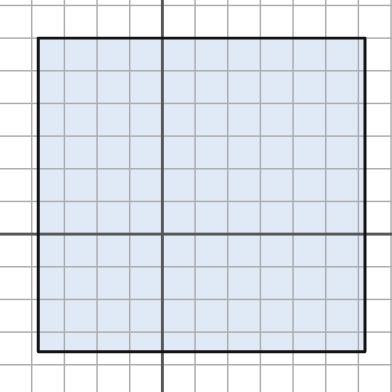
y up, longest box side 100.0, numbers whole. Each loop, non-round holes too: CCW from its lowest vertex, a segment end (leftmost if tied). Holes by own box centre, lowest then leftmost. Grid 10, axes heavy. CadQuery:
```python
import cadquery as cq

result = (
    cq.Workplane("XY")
    .moveTo(-38.0, -36.0)
    .lineTo(62.0, -36.0)
    .lineTo(62.0, 60.0)
    .lineTo(-38.0, 60.0)
    .close()
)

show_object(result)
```